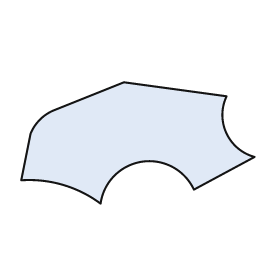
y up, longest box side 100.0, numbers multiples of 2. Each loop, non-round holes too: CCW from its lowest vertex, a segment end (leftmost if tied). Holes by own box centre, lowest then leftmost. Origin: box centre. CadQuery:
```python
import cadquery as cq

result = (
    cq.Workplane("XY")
    .moveTo(-16.0, -26.0)
    .threePointArc((2.0, -8.0), (24.0, -20.0))
    .lineTo(50.0, -6.0)
    .threePointArc((38.0, 4.0), (38.0, 20.0))
    .lineTo(-6.0, 26.0)
    .lineTo(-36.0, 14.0)
    .threePointArc((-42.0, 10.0), (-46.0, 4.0))
    .lineTo(-50.0, -16.0)
    .threePointArc((-32.0, -18.0), (-16.0, -26.0))
    .close()
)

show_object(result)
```